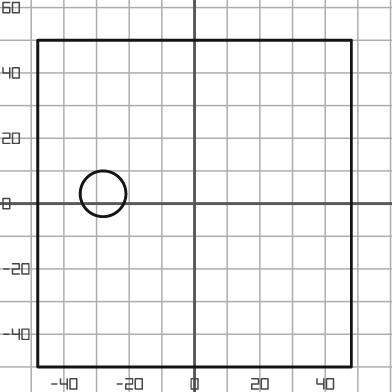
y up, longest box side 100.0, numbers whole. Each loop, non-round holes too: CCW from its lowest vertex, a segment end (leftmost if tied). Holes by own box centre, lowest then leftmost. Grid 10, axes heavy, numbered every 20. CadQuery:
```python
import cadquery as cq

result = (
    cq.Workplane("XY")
    .moveTo(-48.0, -50.0)
    .lineTo(48.0, -50.0)
    .lineTo(48.0, 50.0)
    .lineTo(-48.0, 50.0)
    .close()
    .moveTo(-28.0, 3.0)
    .circle(7.0)
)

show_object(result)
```